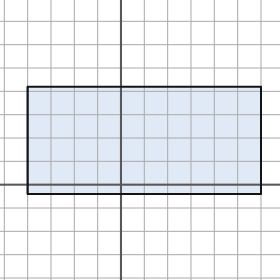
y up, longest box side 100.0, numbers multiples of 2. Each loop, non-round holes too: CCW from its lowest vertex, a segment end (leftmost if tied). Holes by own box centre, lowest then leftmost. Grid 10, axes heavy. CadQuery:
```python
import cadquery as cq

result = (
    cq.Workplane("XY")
    .moveTo(-40.0, -4.0)
    .lineTo(60.0, -4.0)
    .lineTo(60.0, 42.0)
    .lineTo(-40.0, 42.0)
    .close()
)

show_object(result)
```